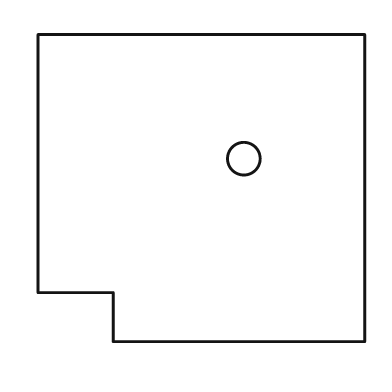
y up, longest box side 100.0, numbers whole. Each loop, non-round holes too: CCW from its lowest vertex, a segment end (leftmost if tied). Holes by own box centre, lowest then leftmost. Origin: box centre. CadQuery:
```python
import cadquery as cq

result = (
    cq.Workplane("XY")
    .moveTo(-27.0, -47.0)
    .lineTo(50.0, -47.0)
    .lineTo(50.0, 47.0)
    .lineTo(-50.0, 47.0)
    .lineTo(-50.0, -32.0)
    .lineTo(-27.0, -32.0)
    .close()
    .moveTo(13.0, 9.0)
    .circle(5.0)
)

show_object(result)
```